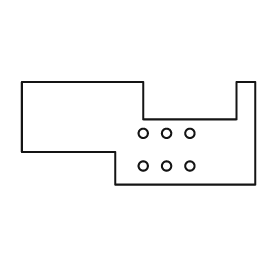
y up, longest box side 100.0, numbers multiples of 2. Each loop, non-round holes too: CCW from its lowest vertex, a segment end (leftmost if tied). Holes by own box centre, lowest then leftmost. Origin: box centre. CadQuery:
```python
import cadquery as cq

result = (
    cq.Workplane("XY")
    .moveTo(-10.0, -22.0)
    .lineTo(50.0, -22.0)
    .lineTo(50.0, 22.0)
    .lineTo(42.0, 22.0)
    .lineTo(42.0, 6.0)
    .lineTo(2.0, 6.0)
    .lineTo(2.0, 22.0)
    .lineTo(-50.0, 22.0)
    .lineTo(-50.0, -8.0)
    .lineTo(-10.0, -8.0)
    .close()
    .moveTo(2.0, -14.0)
    .circle(2.0)
    .moveTo(12.0, -14.0)
    .circle(2.0)
    .moveTo(22.0, -14.0)
    .circle(2.0)
    .moveTo(2.0, 0.0)
    .circle(2.0)
    .moveTo(12.0, 0.0)
    .circle(2.0)
    .moveTo(22.0, 0.0)
    .circle(2.0)
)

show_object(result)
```